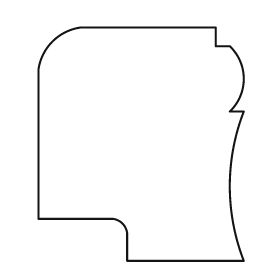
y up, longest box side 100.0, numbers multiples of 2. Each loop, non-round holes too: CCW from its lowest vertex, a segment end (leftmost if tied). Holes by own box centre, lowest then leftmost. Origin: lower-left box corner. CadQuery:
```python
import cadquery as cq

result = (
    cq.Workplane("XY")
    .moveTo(38.0, 0.0)
    .lineTo(88.0, 0.0)
    .threePointArc((82.0, 32.0), (88.0, 64.0))
    .lineTo(82.0, 64.0)
    .threePointArc((88.0, 78.0), (82.0, 92.0))
    .lineTo(76.0, 92.0)
    .lineTo(76.0, 100.0)
    .lineTo(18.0, 100.0)
    .threePointArc((6.0, 94.0), (0.0, 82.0))
    .lineTo(0.0, 18.0)
    .lineTo(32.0, 18.0)
    .threePointArc((36.0, 16.0), (38.0, 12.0))
    .close()
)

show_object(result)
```